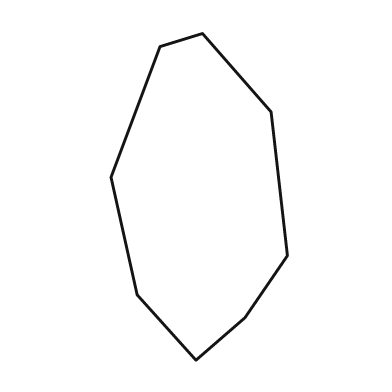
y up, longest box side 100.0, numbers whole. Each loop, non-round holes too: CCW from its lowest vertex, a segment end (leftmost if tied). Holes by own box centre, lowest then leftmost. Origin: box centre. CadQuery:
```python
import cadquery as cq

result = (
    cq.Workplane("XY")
    .moveTo(-1.0, -50.0)
    .lineTo(14.0, -37.0)
    .lineTo(27.0, -18.0)
    .lineTo(22.0, 26.0)
    .lineTo(1.0, 50.0)
    .lineTo(-12.0, 46.0)
    .lineTo(-27.0, 6.0)
    .lineTo(-19.0, -30.0)
    .close()
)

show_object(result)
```